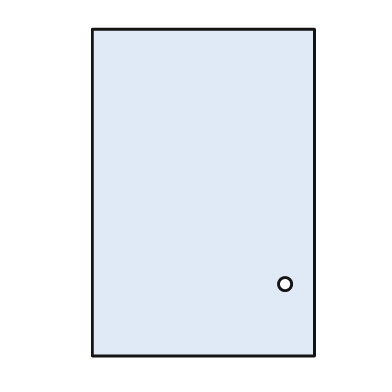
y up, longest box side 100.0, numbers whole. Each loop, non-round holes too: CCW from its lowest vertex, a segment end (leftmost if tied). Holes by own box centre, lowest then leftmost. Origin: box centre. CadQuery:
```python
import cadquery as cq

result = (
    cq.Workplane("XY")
    .moveTo(-34.0, -50.0)
    .lineTo(34.0, -50.0)
    .lineTo(34.0, 50.0)
    .lineTo(-34.0, 50.0)
    .close()
    .moveTo(25.0, -28.0)
    .circle(2.0)
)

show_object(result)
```